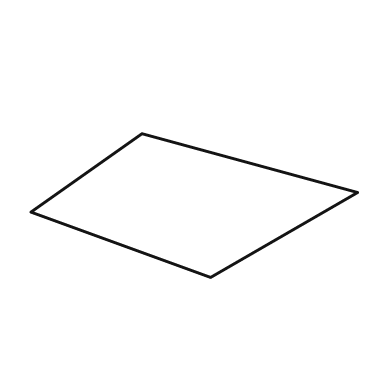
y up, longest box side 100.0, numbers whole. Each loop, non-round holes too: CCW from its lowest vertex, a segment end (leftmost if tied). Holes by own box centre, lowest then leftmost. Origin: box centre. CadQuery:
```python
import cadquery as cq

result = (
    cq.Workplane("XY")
    .moveTo(5.0, -22.0)
    .lineTo(50.0, 4.0)
    .lineTo(-16.0, 22.0)
    .lineTo(-50.0, -2.0)
    .close()
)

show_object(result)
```